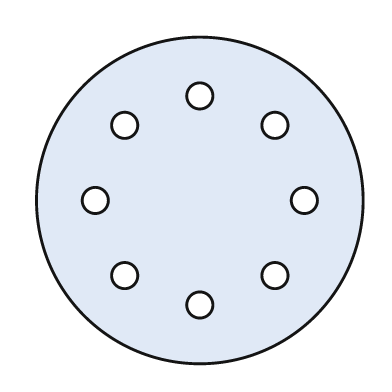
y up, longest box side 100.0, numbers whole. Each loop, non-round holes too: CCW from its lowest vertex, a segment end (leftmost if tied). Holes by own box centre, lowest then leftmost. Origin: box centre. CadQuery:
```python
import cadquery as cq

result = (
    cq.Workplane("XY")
    .moveTo(0.0, 0.0)
    .circle(50.0)
    .moveTo(0.0, -32.0)
    .circle(4.0)
    .moveTo(-23.0, -23.0)
    .circle(4.0)
    .moveTo(23.0, -23.0)
    .circle(4.0)
    .moveTo(-32.0, 0.0)
    .circle(4.0)
    .moveTo(32.0, 0.0)
    .circle(4.0)
    .moveTo(-23.0, 23.0)
    .circle(4.0)
    .moveTo(23.0, 23.0)
    .circle(4.0)
    .moveTo(0.0, 32.0)
    .circle(4.0)
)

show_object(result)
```